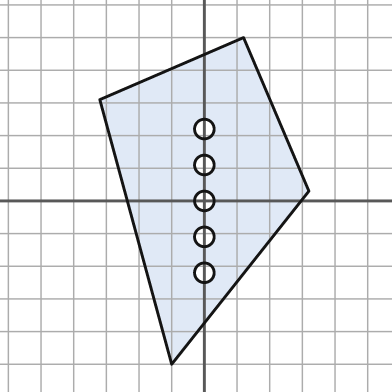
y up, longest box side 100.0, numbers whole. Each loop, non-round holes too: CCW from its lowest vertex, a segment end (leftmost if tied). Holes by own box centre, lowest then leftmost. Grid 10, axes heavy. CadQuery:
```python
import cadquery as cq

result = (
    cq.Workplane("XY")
    .moveTo(-10.0, -50.0)
    .lineTo(32.0, 3.0)
    .lineTo(12.0, 50.0)
    .lineTo(-32.0, 31.0)
    .close()
    .moveTo(0.0, -22.0)
    .circle(3.0)
    .moveTo(0.0, -11.0)
    .circle(3.0)
    .moveTo(0.0, 0.0)
    .circle(3.0)
    .moveTo(0.0, 11.0)
    .circle(3.0)
    .moveTo(0.0, 22.0)
    .circle(3.0)
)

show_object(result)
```